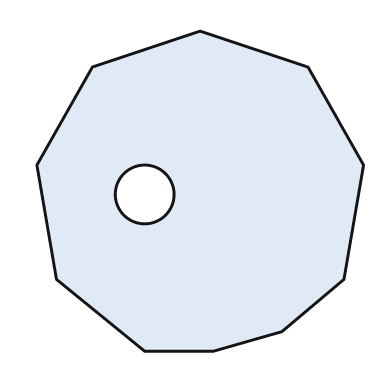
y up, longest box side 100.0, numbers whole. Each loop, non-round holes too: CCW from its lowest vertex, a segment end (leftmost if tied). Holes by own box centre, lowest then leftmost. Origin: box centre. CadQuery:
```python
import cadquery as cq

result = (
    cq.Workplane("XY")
    .moveTo(-17.0, -49.0)
    .lineTo(4.0, -49.0)
    .lineTo(25.0, -43.0)
    .lineTo(44.0, -27.0)
    .lineTo(50.0, 8.0)
    .lineTo(33.0, 38.0)
    .lineTo(0.0, 49.0)
    .lineTo(-33.0, 38.0)
    .lineTo(-50.0, 8.0)
    .lineTo(-44.0, -27.0)
    .close()
    .moveTo(-17.0, -1.0)
    .circle(9.0)
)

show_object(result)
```